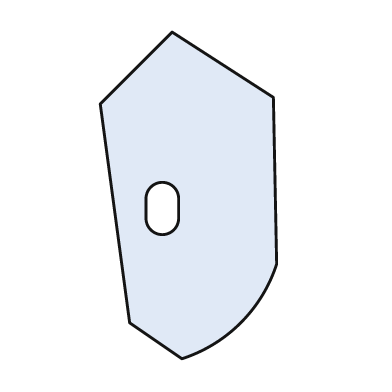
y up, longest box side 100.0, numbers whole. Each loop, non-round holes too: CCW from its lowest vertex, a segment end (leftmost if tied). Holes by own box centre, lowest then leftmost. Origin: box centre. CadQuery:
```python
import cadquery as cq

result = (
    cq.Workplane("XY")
    .moveTo(-2.0, -50.0)
    .threePointArc((16.0, -39.0), (27.0, -21.0))
    .lineTo(26.0, 30.0)
    .lineTo(-5.0, 50.0)
    .lineTo(-27.0, 28.0)
    .lineTo(-18.0, -39.0)
    .close()
    .moveTo(-13.0, -7.0)
    .threePointArc((-8.0, -12.0), (-3.0, -7.0))
    .lineTo(-3.0, -1.0)
    .threePointArc((-8.0, 4.0), (-13.0, -1.0))
    .close()
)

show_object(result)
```